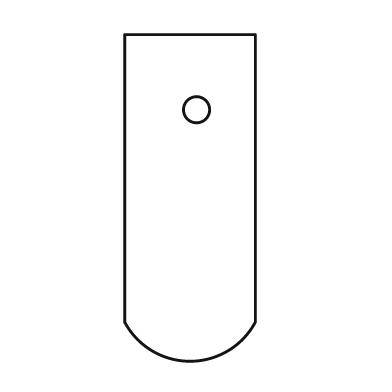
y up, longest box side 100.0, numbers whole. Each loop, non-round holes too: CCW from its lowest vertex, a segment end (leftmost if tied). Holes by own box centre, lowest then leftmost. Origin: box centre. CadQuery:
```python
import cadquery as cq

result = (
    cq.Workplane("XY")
    .moveTo(-20.0, -38.0)
    .threePointArc((0.0, -50.0), (20.0, -38.0))
    .lineTo(20.0, 50.0)
    .lineTo(-20.0, 50.0)
    .close()
    .moveTo(2.0, 27.0)
    .circle(4.0)
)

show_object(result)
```